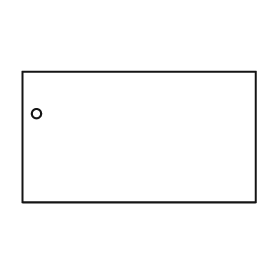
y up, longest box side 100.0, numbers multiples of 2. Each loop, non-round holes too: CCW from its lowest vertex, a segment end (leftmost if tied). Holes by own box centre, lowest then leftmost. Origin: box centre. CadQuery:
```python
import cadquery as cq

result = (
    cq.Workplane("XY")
    .moveTo(-50.0, -28.0)
    .lineTo(50.0, -28.0)
    .lineTo(50.0, 28.0)
    .lineTo(-50.0, 28.0)
    .close()
    .moveTo(-44.0, 10.0)
    .circle(2.0)
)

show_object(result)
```